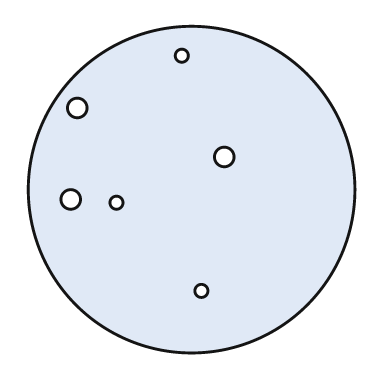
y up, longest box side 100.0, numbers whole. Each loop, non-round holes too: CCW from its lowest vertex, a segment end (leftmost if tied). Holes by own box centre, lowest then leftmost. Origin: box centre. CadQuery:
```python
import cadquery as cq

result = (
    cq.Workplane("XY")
    .moveTo(0.0, 0.0)
    .circle(50.0)
    .moveTo(3.0, -31.0)
    .circle(2.0)
    .moveTo(-23.0, -4.0)
    .circle(2.0)
    .moveTo(-37.0, -3.0)
    .circle(3.0)
    .moveTo(10.0, 10.0)
    .circle(3.0)
    .moveTo(-35.0, 25.0)
    .circle(3.0)
    .moveTo(-3.0, 41.0)
    .circle(2.0)
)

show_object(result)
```